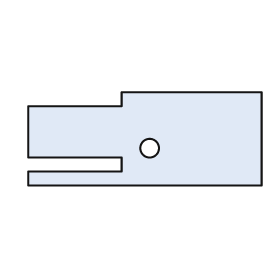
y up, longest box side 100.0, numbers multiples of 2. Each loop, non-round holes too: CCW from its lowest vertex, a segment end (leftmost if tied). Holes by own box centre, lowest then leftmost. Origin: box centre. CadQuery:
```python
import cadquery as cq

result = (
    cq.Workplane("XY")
    .moveTo(-50.0, -20.0)
    .lineTo(50.0, -20.0)
    .lineTo(50.0, 20.0)
    .lineTo(-10.0, 20.0)
    .lineTo(-10.0, 14.0)
    .lineTo(-50.0, 14.0)
    .lineTo(-50.0, -8.0)
    .lineTo(-10.0, -8.0)
    .lineTo(-10.0, -14.0)
    .lineTo(-50.0, -14.0)
    .close()
    .moveTo(2.0, -4.0)
    .circle(4.0)
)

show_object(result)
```